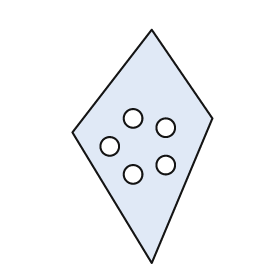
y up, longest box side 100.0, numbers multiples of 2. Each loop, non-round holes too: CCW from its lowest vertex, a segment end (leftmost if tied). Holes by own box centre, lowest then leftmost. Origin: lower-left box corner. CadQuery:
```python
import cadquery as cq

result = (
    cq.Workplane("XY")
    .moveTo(34.0, 0.0)
    .lineTo(60.0, 62.0)
    .lineTo(34.0, 100.0)
    .lineTo(0.0, 56.0)
    .close()
    .moveTo(26.0, 38.0)
    .circle(4.0)
    .moveTo(40.0, 42.0)
    .circle(4.0)
    .moveTo(16.0, 50.0)
    .circle(4.0)
    .moveTo(40.0, 58.0)
    .circle(4.0)
    .moveTo(26.0, 62.0)
    .circle(4.0)
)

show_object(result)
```